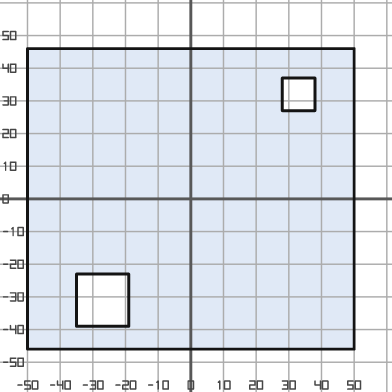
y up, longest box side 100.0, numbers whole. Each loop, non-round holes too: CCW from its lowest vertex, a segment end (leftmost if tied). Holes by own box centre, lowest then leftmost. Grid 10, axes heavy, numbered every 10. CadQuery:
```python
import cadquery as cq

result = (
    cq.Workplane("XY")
    .moveTo(-50.0, -46.0)
    .lineTo(50.0, -46.0)
    .lineTo(50.0, 46.0)
    .lineTo(-50.0, 46.0)
    .close()
    .moveTo(-35.0, -39.0)
    .lineTo(-19.0, -39.0)
    .lineTo(-19.0, -23.0)
    .lineTo(-35.0, -23.0)
    .close()
    .moveTo(28.0, 27.0)
    .lineTo(38.0, 27.0)
    .lineTo(38.0, 37.0)
    .lineTo(28.0, 37.0)
    .close()
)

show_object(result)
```